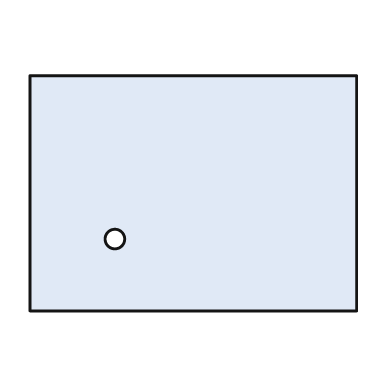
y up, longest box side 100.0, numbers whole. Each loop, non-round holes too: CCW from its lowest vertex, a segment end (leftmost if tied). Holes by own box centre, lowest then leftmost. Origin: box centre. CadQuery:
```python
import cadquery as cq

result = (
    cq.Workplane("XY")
    .moveTo(-50.0, -36.0)
    .lineTo(50.0, -36.0)
    .lineTo(50.0, 36.0)
    .lineTo(-50.0, 36.0)
    .close()
    .moveTo(-24.0, -14.0)
    .circle(3.0)
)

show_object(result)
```